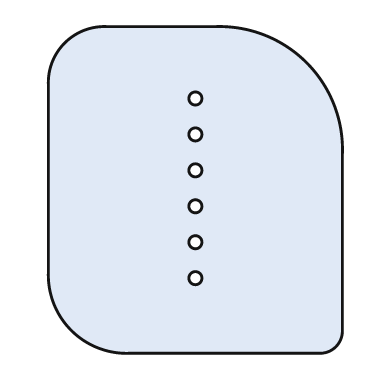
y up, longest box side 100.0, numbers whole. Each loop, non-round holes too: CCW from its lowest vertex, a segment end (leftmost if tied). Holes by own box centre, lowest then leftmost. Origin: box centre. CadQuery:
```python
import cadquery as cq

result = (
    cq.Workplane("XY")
    .moveTo(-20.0, -50.0)
    .lineTo(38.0, -50.0)
    .threePointArc((43.0, -48.0), (45.0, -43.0))
    .lineTo(45.0, 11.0)
    .threePointArc((34.0, 39.0), (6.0, 50.0))
    .lineTo(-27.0, 50.0)
    .threePointArc((-40.0, 45.0), (-45.0, 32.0))
    .lineTo(-45.0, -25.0)
    .threePointArc((-38.0, -43.0), (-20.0, -50.0))
    .close()
    .moveTo(0.0, -27.0)
    .circle(2.0)
    .moveTo(0.0, -16.0)
    .circle(2.0)
    .moveTo(0.0, -5.0)
    .circle(2.0)
    .moveTo(0.0, 6.0)
    .circle(2.0)
    .moveTo(0.0, 17.0)
    .circle(2.0)
    .moveTo(0.0, 28.0)
    .circle(2.0)
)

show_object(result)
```